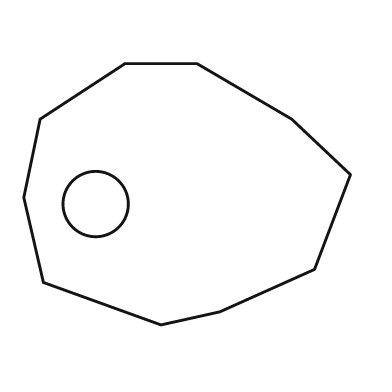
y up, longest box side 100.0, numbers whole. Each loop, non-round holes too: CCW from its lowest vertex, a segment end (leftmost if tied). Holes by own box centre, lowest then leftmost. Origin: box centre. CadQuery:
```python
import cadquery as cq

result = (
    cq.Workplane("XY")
    .moveTo(-8.0, -40.0)
    .lineTo(10.0, -36.0)
    .lineTo(39.0, -23.0)
    .lineTo(50.0, 6.0)
    .lineTo(32.0, 23.0)
    .lineTo(3.0, 40.0)
    .lineTo(-19.0, 40.0)
    .lineTo(-45.0, 23.0)
    .lineTo(-50.0, -1.0)
    .lineTo(-44.0, -27.0)
    .close()
    .moveTo(-28.0, -3.0)
    .circle(10.0)
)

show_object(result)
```